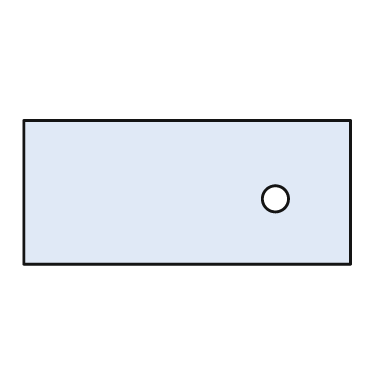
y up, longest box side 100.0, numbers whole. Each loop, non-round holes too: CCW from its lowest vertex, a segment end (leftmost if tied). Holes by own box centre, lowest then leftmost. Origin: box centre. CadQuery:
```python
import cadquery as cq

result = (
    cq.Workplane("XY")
    .moveTo(-50.0, -22.0)
    .lineTo(50.0, -22.0)
    .lineTo(50.0, 22.0)
    .lineTo(-50.0, 22.0)
    .close()
    .moveTo(27.0, -2.0)
    .circle(4.0)
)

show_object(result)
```